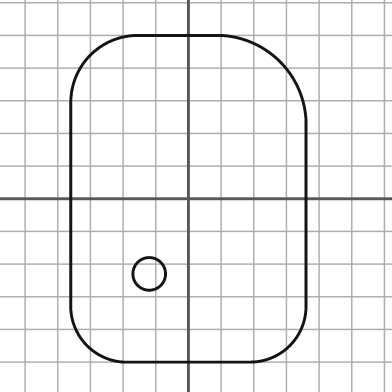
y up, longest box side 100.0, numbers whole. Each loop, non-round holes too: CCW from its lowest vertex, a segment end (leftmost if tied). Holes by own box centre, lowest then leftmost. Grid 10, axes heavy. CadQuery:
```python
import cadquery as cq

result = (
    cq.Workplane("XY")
    .moveTo(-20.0, -50.0)
    .lineTo(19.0, -50.0)
    .threePointArc((31.0, -45.0), (36.0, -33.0))
    .lineTo(36.0, 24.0)
    .threePointArc((28.0, 42.0), (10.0, 50.0))
    .lineTo(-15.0, 50.0)
    .threePointArc((-30.0, 44.0), (-36.0, 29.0))
    .lineTo(-36.0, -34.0)
    .threePointArc((-31.0, -45.0), (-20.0, -50.0))
    .close()
    .moveTo(-12.0, -23.0)
    .circle(5.0)
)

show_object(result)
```